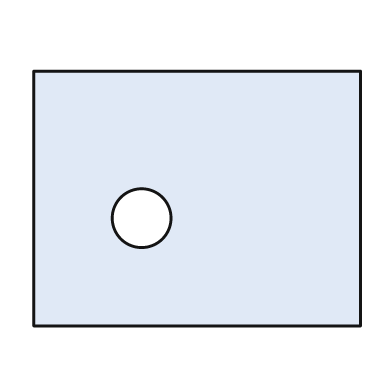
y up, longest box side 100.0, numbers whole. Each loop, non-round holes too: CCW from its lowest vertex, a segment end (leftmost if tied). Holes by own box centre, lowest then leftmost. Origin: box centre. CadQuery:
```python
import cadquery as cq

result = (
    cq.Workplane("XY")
    .moveTo(-50.0, -39.0)
    .lineTo(50.0, -39.0)
    .lineTo(50.0, 39.0)
    .lineTo(-50.0, 39.0)
    .close()
    .moveTo(-17.0, -6.0)
    .circle(9.0)
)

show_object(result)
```